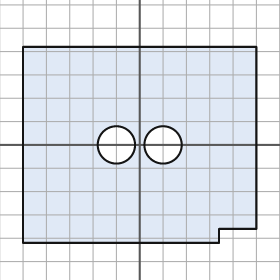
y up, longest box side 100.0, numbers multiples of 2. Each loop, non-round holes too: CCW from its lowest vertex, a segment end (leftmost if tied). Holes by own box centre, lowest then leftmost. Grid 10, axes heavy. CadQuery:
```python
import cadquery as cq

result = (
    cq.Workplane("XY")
    .moveTo(-50.0, -42.0)
    .lineTo(34.0, -42.0)
    .lineTo(34.0, -36.0)
    .lineTo(50.0, -36.0)
    .lineTo(50.0, 42.0)
    .lineTo(-50.0, 42.0)
    .close()
    .moveTo(-10.0, 0.0)
    .circle(8.0)
    .moveTo(10.0, 0.0)
    .circle(8.0)
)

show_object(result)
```